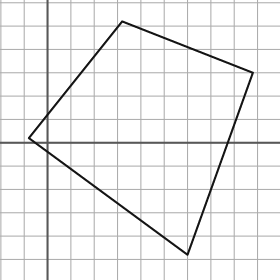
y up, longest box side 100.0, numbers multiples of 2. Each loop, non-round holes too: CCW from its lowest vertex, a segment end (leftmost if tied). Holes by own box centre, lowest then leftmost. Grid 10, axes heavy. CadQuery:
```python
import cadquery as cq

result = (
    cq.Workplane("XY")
    .moveTo(60.0, -48.0)
    .lineTo(88.0, 30.0)
    .lineTo(32.0, 52.0)
    .lineTo(-8.0, 2.0)
    .close()
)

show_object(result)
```